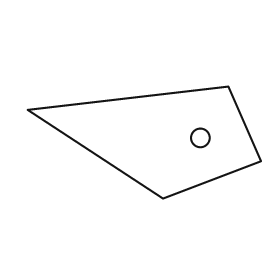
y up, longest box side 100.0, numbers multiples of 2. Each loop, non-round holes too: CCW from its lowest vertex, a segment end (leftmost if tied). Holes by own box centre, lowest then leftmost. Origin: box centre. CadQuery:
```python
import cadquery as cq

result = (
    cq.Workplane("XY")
    .moveTo(8.0, -24.0)
    .lineTo(50.0, -8.0)
    .lineTo(36.0, 24.0)
    .lineTo(-50.0, 14.0)
    .close()
    .moveTo(24.0, 2.0)
    .circle(4.0)
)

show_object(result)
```